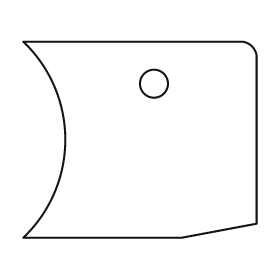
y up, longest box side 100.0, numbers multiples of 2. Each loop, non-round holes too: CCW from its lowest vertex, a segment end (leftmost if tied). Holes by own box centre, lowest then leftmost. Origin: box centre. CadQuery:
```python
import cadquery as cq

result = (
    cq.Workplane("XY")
    .moveTo(-50.0, -42.0)
    .lineTo(18.0, -42.0)
    .lineTo(50.0, -36.0)
    .lineTo(50.0, 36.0)
    .threePointArc((48.0, 40.0), (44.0, 42.0))
    .lineTo(-50.0, 42.0)
    .threePointArc((-32.0, 0.0), (-50.0, -42.0))
    .close()
    .moveTo(6.0, 24.0)
    .circle(6.0)
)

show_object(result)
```